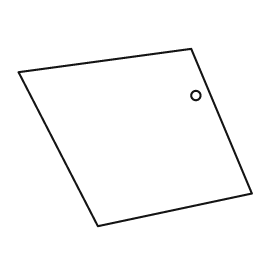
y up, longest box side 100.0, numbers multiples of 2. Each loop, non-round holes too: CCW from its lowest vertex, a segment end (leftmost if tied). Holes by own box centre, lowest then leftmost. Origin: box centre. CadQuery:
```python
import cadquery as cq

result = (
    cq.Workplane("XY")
    .moveTo(-16.0, -38.0)
    .lineTo(50.0, -24.0)
    .lineTo(24.0, 38.0)
    .lineTo(-50.0, 28.0)
    .close()
    .moveTo(26.0, 18.0)
    .circle(2.0)
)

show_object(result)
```